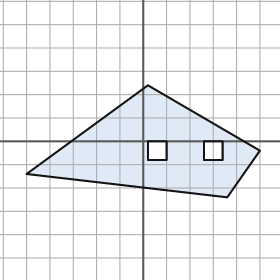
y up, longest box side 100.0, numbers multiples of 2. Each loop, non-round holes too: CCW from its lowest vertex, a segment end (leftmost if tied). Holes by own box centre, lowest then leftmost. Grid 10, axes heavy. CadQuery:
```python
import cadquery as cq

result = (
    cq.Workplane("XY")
    .moveTo(36.0, -24.0)
    .lineTo(50.0, -4.0)
    .lineTo(2.0, 24.0)
    .lineTo(-50.0, -14.0)
    .close()
    .moveTo(2.0, -8.0)
    .lineTo(10.0, -8.0)
    .lineTo(10.0, 0.0)
    .lineTo(2.0, 0.0)
    .close()
    .moveTo(26.0, -8.0)
    .lineTo(34.0, -8.0)
    .lineTo(34.0, 0.0)
    .lineTo(26.0, 0.0)
    .close()
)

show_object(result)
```